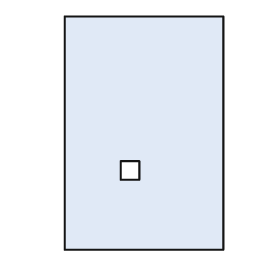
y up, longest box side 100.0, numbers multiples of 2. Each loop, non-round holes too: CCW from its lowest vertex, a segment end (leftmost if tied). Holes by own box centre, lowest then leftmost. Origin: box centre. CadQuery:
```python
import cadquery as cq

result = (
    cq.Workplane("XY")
    .moveTo(-34.0, -50.0)
    .lineTo(34.0, -50.0)
    .lineTo(34.0, 50.0)
    .lineTo(-34.0, 50.0)
    .close()
    .moveTo(-10.0, -20.0)
    .lineTo(-2.0, -20.0)
    .lineTo(-2.0, -12.0)
    .lineTo(-10.0, -12.0)
    .close()
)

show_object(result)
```